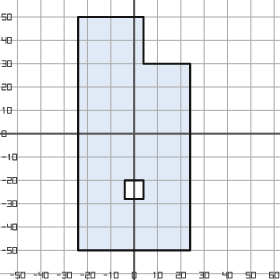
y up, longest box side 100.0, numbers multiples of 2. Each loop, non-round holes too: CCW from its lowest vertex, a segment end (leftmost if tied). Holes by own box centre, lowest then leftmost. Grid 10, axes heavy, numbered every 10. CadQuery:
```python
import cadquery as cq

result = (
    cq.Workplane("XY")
    .moveTo(-24.0, -50.0)
    .lineTo(24.0, -50.0)
    .lineTo(24.0, 30.0)
    .lineTo(4.0, 30.0)
    .lineTo(4.0, 50.0)
    .lineTo(-24.0, 50.0)
    .close()
    .moveTo(-4.0, -28.0)
    .lineTo(4.0, -28.0)
    .lineTo(4.0, -20.0)
    .lineTo(-4.0, -20.0)
    .close()
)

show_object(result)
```